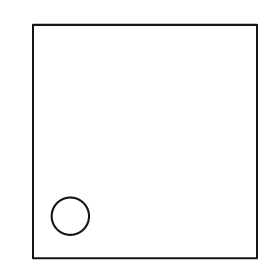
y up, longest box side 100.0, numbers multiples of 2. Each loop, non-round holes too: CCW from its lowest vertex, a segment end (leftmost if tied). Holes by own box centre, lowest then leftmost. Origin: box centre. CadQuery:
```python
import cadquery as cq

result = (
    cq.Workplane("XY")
    .moveTo(-48.0, -50.0)
    .lineTo(48.0, -50.0)
    .lineTo(48.0, 50.0)
    .lineTo(-48.0, 50.0)
    .close()
    .moveTo(-32.0, -32.0)
    .circle(8.0)
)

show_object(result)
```